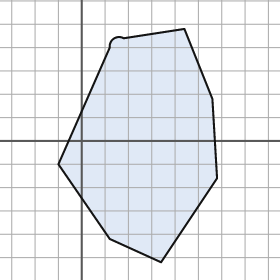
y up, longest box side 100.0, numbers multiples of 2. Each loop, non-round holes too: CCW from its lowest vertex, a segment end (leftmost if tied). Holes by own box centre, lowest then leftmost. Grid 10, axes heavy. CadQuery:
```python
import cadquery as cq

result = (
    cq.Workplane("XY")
    .moveTo(34.0, -52.0)
    .lineTo(58.0, -16.0)
    .lineTo(56.0, 18.0)
    .lineTo(44.0, 48.0)
    .lineTo(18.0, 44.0)
    .threePointArc((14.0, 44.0), (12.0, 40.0))
    .lineTo(-10.0, -10.0)
    .lineTo(12.0, -42.0)
    .close()
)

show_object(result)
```